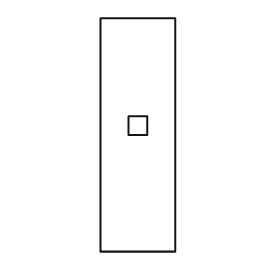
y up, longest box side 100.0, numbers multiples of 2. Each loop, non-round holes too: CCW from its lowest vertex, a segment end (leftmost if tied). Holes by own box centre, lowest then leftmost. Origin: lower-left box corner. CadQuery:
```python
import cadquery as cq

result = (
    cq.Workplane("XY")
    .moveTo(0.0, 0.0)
    .lineTo(32.0, 0.0)
    .lineTo(32.0, 100.0)
    .lineTo(0.0, 100.0)
    .close()
    .moveTo(12.0, 50.0)
    .lineTo(20.0, 50.0)
    .lineTo(20.0, 58.0)
    .lineTo(12.0, 58.0)
    .close()
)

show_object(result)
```